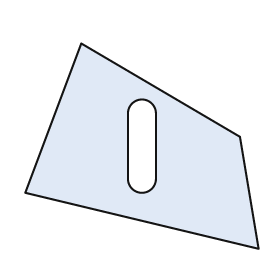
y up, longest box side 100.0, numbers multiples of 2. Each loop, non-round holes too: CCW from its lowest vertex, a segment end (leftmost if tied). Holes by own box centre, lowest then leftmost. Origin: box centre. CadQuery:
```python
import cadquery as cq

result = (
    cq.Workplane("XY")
    .moveTo(50.0, -44.0)
    .lineTo(42.0, 4.0)
    .lineTo(-26.0, 44.0)
    .lineTo(-50.0, -20.0)
    .close()
    .moveTo(-6.0, -14.0)
    .threePointArc((0.0, -20.0), (6.0, -14.0))
    .lineTo(6.0, 14.0)
    .threePointArc((0.0, 20.0), (-6.0, 14.0))
    .close()
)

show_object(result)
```